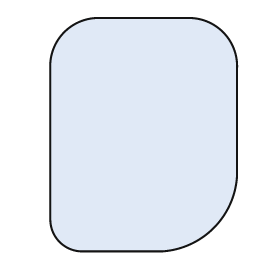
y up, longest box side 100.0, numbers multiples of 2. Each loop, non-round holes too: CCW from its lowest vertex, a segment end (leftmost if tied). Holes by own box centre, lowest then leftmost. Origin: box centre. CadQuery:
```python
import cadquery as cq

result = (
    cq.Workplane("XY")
    .moveTo(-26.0, -50.0)
    .lineTo(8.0, -50.0)
    .threePointArc((30.0, -40.0), (40.0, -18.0))
    .lineTo(40.0, 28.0)
    .threePointArc((34.0, 44.0), (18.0, 50.0))
    .lineTo(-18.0, 50.0)
    .threePointArc((-34.0, 44.0), (-40.0, 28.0))
    .lineTo(-40.0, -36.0)
    .threePointArc((-36.0, -46.0), (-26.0, -50.0))
    .close()
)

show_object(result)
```